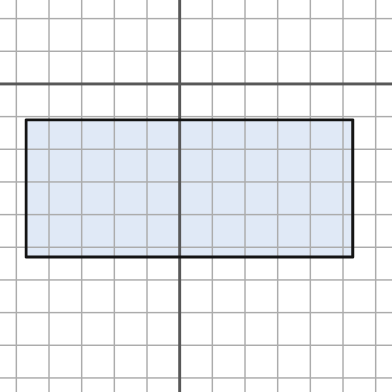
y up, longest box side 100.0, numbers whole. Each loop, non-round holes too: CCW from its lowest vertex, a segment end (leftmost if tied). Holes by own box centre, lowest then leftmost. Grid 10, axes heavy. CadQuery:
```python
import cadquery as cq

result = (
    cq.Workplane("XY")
    .moveTo(-47.0, -53.0)
    .lineTo(53.0, -53.0)
    .lineTo(53.0, -11.0)
    .lineTo(-47.0, -11.0)
    .close()
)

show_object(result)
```